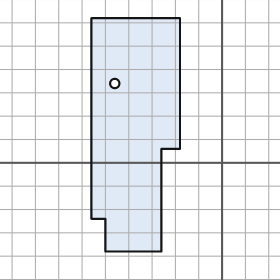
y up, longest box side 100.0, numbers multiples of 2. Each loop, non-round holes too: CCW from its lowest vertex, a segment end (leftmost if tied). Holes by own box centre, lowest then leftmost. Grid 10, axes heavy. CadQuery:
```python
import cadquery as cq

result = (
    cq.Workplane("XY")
    .moveTo(-50.0, -38.0)
    .lineTo(-26.0, -38.0)
    .lineTo(-26.0, 6.0)
    .lineTo(-18.0, 6.0)
    .lineTo(-18.0, 62.0)
    .lineTo(-56.0, 62.0)
    .lineTo(-56.0, -24.0)
    .lineTo(-50.0, -24.0)
    .close()
    .moveTo(-46.0, 34.0)
    .circle(2.0)
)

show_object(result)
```